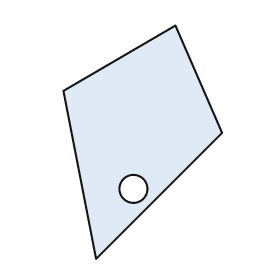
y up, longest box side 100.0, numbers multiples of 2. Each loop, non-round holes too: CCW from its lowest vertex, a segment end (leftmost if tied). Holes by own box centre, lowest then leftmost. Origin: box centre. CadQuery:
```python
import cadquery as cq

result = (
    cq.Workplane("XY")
    .moveTo(-20.0, -50.0)
    .lineTo(34.0, 4.0)
    .lineTo(14.0, 50.0)
    .lineTo(-34.0, 22.0)
    .close()
    .moveTo(-4.0, -20.0)
    .circle(6.0)
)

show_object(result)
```